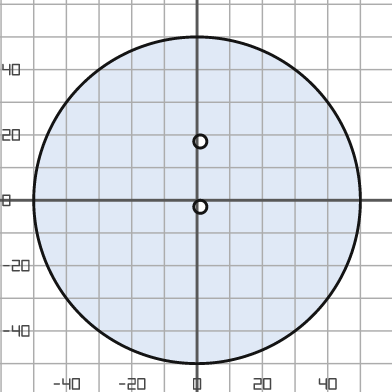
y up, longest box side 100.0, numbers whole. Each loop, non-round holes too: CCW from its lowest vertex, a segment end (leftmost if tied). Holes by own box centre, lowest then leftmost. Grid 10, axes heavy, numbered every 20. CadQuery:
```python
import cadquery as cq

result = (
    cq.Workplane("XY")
    .moveTo(0.0, 0.0)
    .circle(50.0)
    .moveTo(1.0, -2.0)
    .circle(2.0)
    .moveTo(1.0, 18.0)
    .circle(2.0)
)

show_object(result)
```